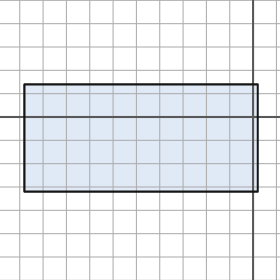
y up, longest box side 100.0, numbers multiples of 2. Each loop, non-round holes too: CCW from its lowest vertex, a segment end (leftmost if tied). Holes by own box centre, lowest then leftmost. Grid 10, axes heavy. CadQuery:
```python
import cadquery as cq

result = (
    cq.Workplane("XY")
    .moveTo(-98.0, -32.0)
    .lineTo(2.0, -32.0)
    .lineTo(2.0, 14.0)
    .lineTo(-98.0, 14.0)
    .close()
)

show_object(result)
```